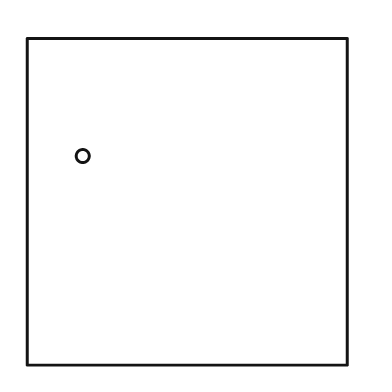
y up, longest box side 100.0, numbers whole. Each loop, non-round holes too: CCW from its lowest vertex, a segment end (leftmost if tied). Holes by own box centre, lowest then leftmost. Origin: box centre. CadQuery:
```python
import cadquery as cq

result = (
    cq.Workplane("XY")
    .moveTo(-49.0, -50.0)
    .lineTo(49.0, -50.0)
    .lineTo(49.0, 50.0)
    .lineTo(-49.0, 50.0)
    .close()
    .moveTo(-32.0, 14.0)
    .circle(2.0)
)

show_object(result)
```